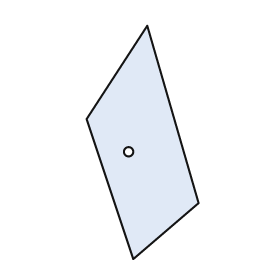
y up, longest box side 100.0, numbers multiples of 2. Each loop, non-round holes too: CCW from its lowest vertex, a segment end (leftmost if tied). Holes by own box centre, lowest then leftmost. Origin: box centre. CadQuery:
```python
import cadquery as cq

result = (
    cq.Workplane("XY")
    .moveTo(-4.0, -50.0)
    .lineTo(24.0, -26.0)
    .lineTo(2.0, 50.0)
    .lineTo(-24.0, 10.0)
    .close()
    .moveTo(-6.0, -4.0)
    .circle(2.0)
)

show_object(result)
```